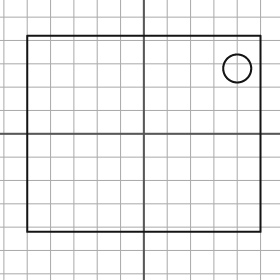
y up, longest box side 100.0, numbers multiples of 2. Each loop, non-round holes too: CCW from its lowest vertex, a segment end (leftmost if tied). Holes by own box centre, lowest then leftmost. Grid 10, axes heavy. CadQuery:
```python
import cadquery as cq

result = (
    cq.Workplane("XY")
    .moveTo(-50.0, -42.0)
    .lineTo(50.0, -42.0)
    .lineTo(50.0, 42.0)
    .lineTo(-50.0, 42.0)
    .close()
    .moveTo(40.0, 28.0)
    .circle(6.0)
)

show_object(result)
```